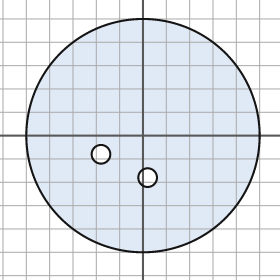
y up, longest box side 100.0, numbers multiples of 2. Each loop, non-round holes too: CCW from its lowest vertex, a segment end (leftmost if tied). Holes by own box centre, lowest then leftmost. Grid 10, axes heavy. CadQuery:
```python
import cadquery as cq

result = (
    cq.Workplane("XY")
    .moveTo(0.0, 0.0)
    .circle(50.0)
    .moveTo(2.0, -18.0)
    .circle(4.0)
    .moveTo(-18.0, -8.0)
    .circle(4.0)
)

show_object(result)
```